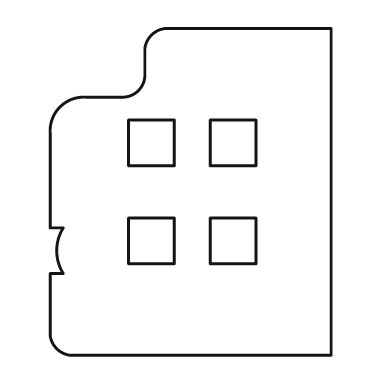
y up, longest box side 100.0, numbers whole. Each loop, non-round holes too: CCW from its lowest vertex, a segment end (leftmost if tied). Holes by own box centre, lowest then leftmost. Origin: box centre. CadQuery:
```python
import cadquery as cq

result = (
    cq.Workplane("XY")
    .moveTo(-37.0, -50.0)
    .lineTo(43.0, -50.0)
    .lineTo(43.0, 50.0)
    .lineTo(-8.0, 50.0)
    .threePointArc((-12.0, 48.0), (-14.0, 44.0))
    .lineTo(-14.0, 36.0)
    .threePointArc((-16.0, 31.0), (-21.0, 29.0))
    .lineTo(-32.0, 29.0)
    .threePointArc((-40.0, 26.0), (-43.0, 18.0))
    .lineTo(-43.0, -11.0)
    .lineTo(-39.0, -11.0)
    .threePointArc((-41.0, -18.0), (-39.0, -25.0))
    .lineTo(-43.0, -25.0)
    .lineTo(-43.0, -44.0)
    .threePointArc((-41.0, -48.0), (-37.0, -50.0))
    .close()
    .moveTo(-19.0, -22.0)
    .lineTo(-5.0, -22.0)
    .lineTo(-5.0, -8.0)
    .lineTo(-19.0, -8.0)
    .close()
    .moveTo(6.0, -22.0)
    .lineTo(20.0, -22.0)
    .lineTo(20.0, -8.0)
    .lineTo(6.0, -8.0)
    .close()
    .moveTo(-19.0, 8.0)
    .lineTo(-5.0, 8.0)
    .lineTo(-5.0, 22.0)
    .lineTo(-19.0, 22.0)
    .close()
    .moveTo(6.0, 8.0)
    .lineTo(20.0, 8.0)
    .lineTo(20.0, 22.0)
    .lineTo(6.0, 22.0)
    .close()
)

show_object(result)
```